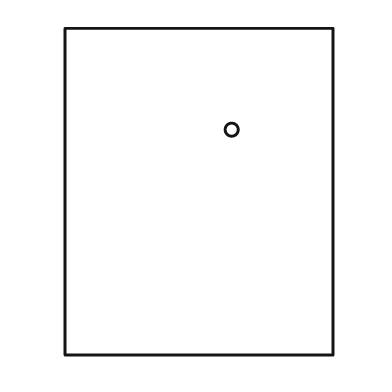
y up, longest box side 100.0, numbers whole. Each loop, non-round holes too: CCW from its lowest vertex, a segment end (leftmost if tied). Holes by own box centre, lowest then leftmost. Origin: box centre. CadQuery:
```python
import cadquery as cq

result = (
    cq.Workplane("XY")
    .moveTo(-41.0, -50.0)
    .lineTo(41.0, -50.0)
    .lineTo(41.0, 50.0)
    .lineTo(-41.0, 50.0)
    .close()
    .moveTo(10.0, 19.0)
    .circle(2.0)
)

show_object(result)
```